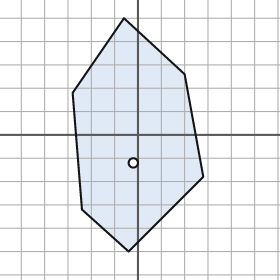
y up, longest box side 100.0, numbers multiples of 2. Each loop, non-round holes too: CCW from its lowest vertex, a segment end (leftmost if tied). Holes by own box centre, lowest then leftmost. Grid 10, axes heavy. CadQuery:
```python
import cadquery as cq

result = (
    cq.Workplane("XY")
    .moveTo(-4.0, -50.0)
    .lineTo(28.0, -18.0)
    .lineTo(20.0, 26.0)
    .lineTo(-6.0, 50.0)
    .lineTo(-28.0, 18.0)
    .lineTo(-24.0, -32.0)
    .close()
    .moveTo(-2.0, -12.0)
    .circle(2.0)
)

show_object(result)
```